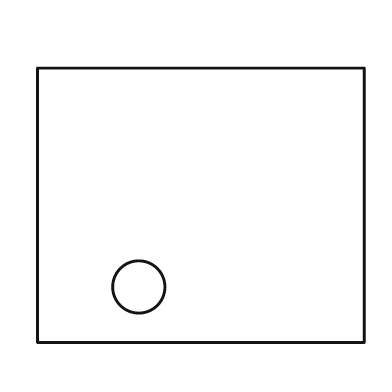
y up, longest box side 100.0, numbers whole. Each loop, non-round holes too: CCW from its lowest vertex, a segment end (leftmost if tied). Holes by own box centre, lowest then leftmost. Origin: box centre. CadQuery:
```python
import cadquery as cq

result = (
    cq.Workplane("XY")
    .moveTo(-50.0, -42.0)
    .lineTo(50.0, -42.0)
    .lineTo(50.0, 42.0)
    .lineTo(-50.0, 42.0)
    .close()
    .moveTo(-19.0, -25.0)
    .circle(8.0)
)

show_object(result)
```